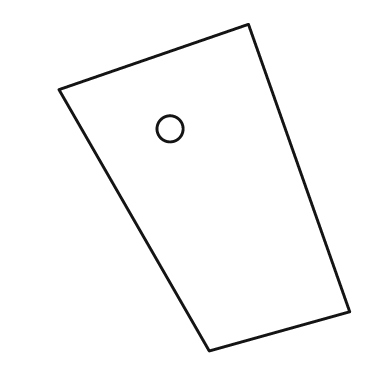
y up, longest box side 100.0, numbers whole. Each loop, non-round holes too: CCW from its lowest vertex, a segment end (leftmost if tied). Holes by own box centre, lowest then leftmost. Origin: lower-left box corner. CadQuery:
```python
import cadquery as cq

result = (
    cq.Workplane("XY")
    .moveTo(46.0, 0.0)
    .lineTo(89.0, 12.0)
    .lineTo(58.0, 100.0)
    .lineTo(0.0, 80.0)
    .close()
    .moveTo(34.0, 68.0)
    .circle(4.0)
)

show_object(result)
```